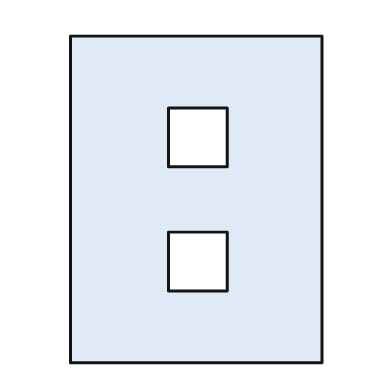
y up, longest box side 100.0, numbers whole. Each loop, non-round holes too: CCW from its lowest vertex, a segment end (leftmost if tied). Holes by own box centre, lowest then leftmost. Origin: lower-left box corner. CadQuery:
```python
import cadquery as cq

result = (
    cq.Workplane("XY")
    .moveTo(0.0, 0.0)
    .lineTo(77.0, 0.0)
    .lineTo(77.0, 100.0)
    .lineTo(0.0, 100.0)
    .close()
    .moveTo(30.0, 22.0)
    .lineTo(48.0, 22.0)
    .lineTo(48.0, 40.0)
    .lineTo(30.0, 40.0)
    .close()
    .moveTo(30.0, 60.0)
    .lineTo(48.0, 60.0)
    .lineTo(48.0, 78.0)
    .lineTo(30.0, 78.0)
    .close()
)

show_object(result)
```